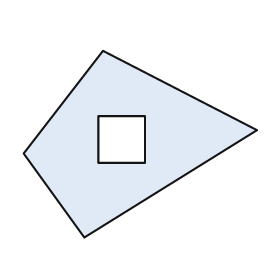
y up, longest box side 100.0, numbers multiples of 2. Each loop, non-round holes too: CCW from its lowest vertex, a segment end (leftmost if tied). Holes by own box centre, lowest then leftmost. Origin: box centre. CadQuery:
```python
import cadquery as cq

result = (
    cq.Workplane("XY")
    .moveTo(-24.0, -40.0)
    .lineTo(50.0, 6.0)
    .lineTo(-16.0, 40.0)
    .lineTo(-50.0, -4.0)
    .close()
    .moveTo(-18.0, -8.0)
    .lineTo(2.0, -8.0)
    .lineTo(2.0, 12.0)
    .lineTo(-18.0, 12.0)
    .close()
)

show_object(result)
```